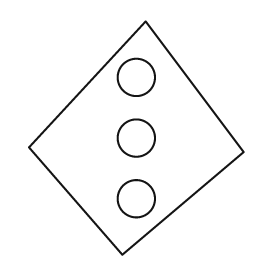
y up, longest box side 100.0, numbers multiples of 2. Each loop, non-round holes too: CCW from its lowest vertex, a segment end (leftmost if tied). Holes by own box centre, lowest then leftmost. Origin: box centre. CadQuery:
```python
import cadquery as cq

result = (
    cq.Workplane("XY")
    .moveTo(-6.0, -50.0)
    .lineTo(46.0, -6.0)
    .lineTo(4.0, 50.0)
    .lineTo(-46.0, -4.0)
    .close()
    .moveTo(0.0, -26.0)
    .circle(8.0)
    .moveTo(0.0, 0.0)
    .circle(8.0)
    .moveTo(0.0, 26.0)
    .circle(8.0)
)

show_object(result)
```